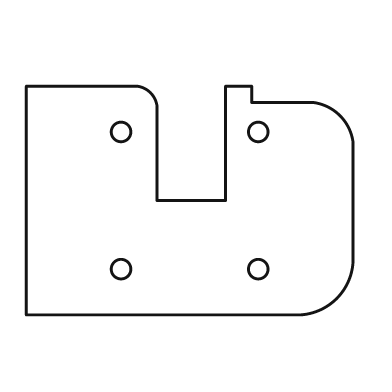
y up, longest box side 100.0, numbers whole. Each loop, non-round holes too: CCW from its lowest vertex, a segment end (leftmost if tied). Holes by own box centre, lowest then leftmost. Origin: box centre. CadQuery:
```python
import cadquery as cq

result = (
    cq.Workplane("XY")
    .moveTo(-50.0, -35.0)
    .lineTo(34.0, -35.0)
    .threePointArc((45.0, -30.0), (50.0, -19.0))
    .lineTo(50.0, 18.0)
    .threePointArc((46.0, 26.0), (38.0, 30.0))
    .lineTo(19.0, 30.0)
    .lineTo(19.0, 35.0)
    .lineTo(11.0, 35.0)
    .lineTo(11.0, 0.0)
    .lineTo(-10.0, 0.0)
    .lineTo(-10.0, 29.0)
    .threePointArc((-12.0, 33.0), (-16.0, 35.0))
    .lineTo(-50.0, 35.0)
    .close()
    .moveTo(-21.0, -21.0)
    .circle(3.0)
    .moveTo(21.0, -21.0)
    .circle(3.0)
    .moveTo(-21.0, 21.0)
    .circle(3.0)
    .moveTo(21.0, 21.0)
    .circle(3.0)
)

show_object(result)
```